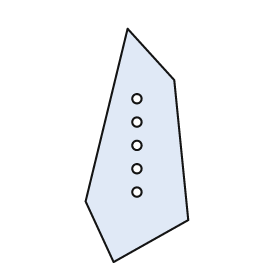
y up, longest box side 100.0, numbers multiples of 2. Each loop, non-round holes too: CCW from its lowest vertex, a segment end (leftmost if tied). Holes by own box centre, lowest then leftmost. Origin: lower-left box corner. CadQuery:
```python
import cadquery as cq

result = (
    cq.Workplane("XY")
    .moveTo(12.0, 0.0)
    .lineTo(44.0, 18.0)
    .lineTo(38.0, 78.0)
    .lineTo(18.0, 100.0)
    .lineTo(0.0, 26.0)
    .close()
    .moveTo(22.0, 30.0)
    .circle(2.0)
    .moveTo(22.0, 40.0)
    .circle(2.0)
    .moveTo(22.0, 50.0)
    .circle(2.0)
    .moveTo(22.0, 60.0)
    .circle(2.0)
    .moveTo(22.0, 70.0)
    .circle(2.0)
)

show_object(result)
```